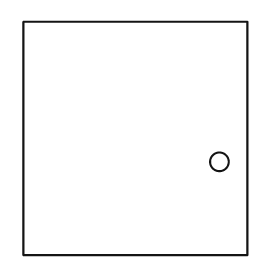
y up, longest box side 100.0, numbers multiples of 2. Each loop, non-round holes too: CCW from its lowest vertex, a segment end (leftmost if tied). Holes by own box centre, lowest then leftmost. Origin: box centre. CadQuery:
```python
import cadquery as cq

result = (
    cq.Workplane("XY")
    .moveTo(-48.0, -50.0)
    .lineTo(48.0, -50.0)
    .lineTo(48.0, 50.0)
    .lineTo(-48.0, 50.0)
    .close()
    .moveTo(36.0, -10.0)
    .circle(4.0)
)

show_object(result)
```